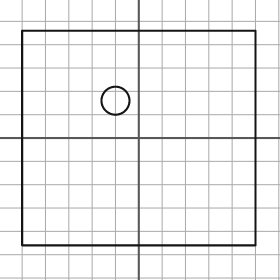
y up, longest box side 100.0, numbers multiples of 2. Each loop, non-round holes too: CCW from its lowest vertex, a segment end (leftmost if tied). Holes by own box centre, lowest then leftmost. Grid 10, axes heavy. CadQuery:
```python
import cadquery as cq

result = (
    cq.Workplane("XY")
    .moveTo(-50.0, -46.0)
    .lineTo(50.0, -46.0)
    .lineTo(50.0, 46.0)
    .lineTo(-50.0, 46.0)
    .close()
    .moveTo(-10.0, 16.0)
    .circle(6.0)
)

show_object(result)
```